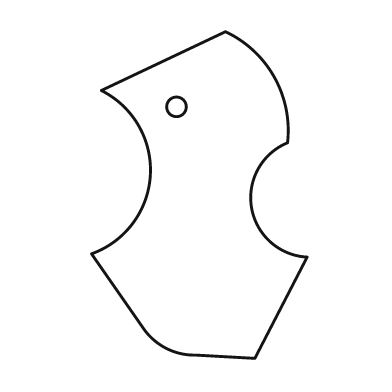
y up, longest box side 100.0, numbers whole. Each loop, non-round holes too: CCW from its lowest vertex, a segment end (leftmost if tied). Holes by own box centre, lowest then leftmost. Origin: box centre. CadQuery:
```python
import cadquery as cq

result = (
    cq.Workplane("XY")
    .moveTo(17.0, -50.0)
    .lineTo(33.0, -19.0)
    .threePointArc((16.0, -4.0), (27.0, 16.0))
    .threePointArc((23.0, 36.0), (8.0, 50.0))
    .lineTo(-30.0, 32.0)
    .threePointArc((-15.0, 6.0), (-33.0, -18.0))
    .lineTo(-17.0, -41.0)
    .threePointArc((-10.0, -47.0), (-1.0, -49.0))
    .close()
    .moveTo(-7.0, 27.0)
    .circle(3.0)
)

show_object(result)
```